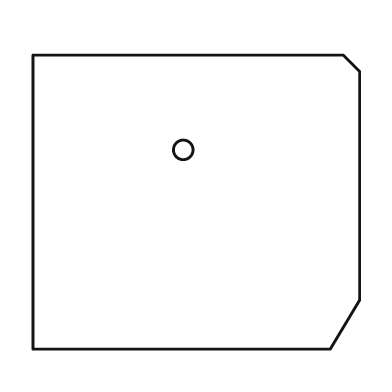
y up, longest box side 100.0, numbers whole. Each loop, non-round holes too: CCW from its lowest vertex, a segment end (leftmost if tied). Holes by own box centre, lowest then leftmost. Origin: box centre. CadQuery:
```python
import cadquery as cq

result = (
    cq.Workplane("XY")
    .moveTo(-50.0, -45.0)
    .lineTo(41.0, -45.0)
    .lineTo(50.0, -30.0)
    .lineTo(50.0, 40.0)
    .lineTo(45.0, 45.0)
    .lineTo(-50.0, 45.0)
    .close()
    .moveTo(-4.0, 16.0)
    .circle(3.0)
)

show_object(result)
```